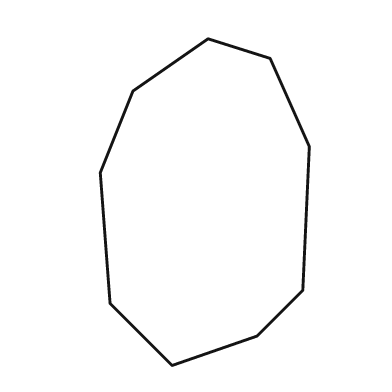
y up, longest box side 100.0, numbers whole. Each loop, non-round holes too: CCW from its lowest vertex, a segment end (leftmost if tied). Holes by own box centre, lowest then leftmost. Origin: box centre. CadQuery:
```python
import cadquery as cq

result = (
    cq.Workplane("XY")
    .moveTo(-10.0, -50.0)
    .lineTo(16.0, -41.0)
    .lineTo(30.0, -27.0)
    .lineTo(32.0, 17.0)
    .lineTo(20.0, 44.0)
    .lineTo(1.0, 50.0)
    .lineTo(-22.0, 34.0)
    .lineTo(-32.0, 9.0)
    .lineTo(-29.0, -31.0)
    .close()
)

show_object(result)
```